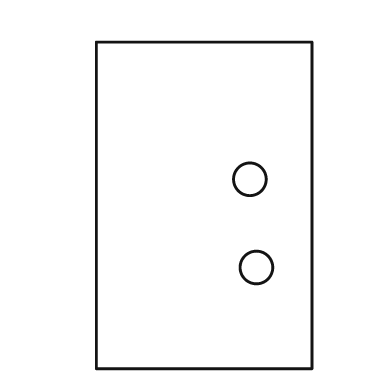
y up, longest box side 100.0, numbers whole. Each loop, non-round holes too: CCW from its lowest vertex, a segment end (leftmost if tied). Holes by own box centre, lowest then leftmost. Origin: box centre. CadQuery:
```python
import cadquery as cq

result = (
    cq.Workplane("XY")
    .moveTo(-33.0, -50.0)
    .lineTo(33.0, -50.0)
    .lineTo(33.0, 50.0)
    .lineTo(-33.0, 50.0)
    .close()
    .moveTo(16.0, -19.0)
    .circle(5.0)
    .moveTo(14.0, 8.0)
    .circle(5.0)
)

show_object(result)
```